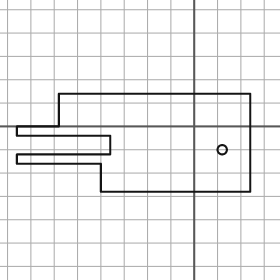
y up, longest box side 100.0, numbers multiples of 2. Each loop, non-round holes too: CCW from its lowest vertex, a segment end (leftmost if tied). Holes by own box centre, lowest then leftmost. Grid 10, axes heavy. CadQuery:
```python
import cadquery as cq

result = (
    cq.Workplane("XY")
    .moveTo(-40.0, -28.0)
    .lineTo(24.0, -28.0)
    .lineTo(24.0, 14.0)
    .lineTo(-58.0, 14.0)
    .lineTo(-58.0, 0.0)
    .lineTo(-76.0, 0.0)
    .lineTo(-76.0, -4.0)
    .lineTo(-36.0, -4.0)
    .lineTo(-36.0, -12.0)
    .lineTo(-76.0, -12.0)
    .lineTo(-76.0, -16.0)
    .lineTo(-40.0, -16.0)
    .close()
    .moveTo(12.0, -10.0)
    .circle(2.0)
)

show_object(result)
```